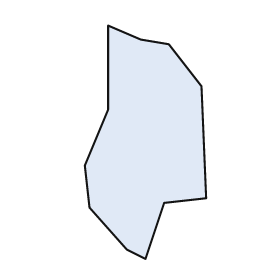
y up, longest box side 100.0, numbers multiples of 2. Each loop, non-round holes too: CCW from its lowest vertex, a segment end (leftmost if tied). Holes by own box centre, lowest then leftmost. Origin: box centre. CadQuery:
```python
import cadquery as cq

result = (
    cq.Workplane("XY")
    .moveTo(0.0, -50.0)
    .lineTo(8.0, -26.0)
    .lineTo(26.0, -24.0)
    .lineTo(24.0, 24.0)
    .lineTo(10.0, 42.0)
    .lineTo(-2.0, 44.0)
    .lineTo(-16.0, 50.0)
    .lineTo(-16.0, 14.0)
    .lineTo(-26.0, -10.0)
    .lineTo(-24.0, -28.0)
    .lineTo(-8.0, -46.0)
    .close()
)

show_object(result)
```